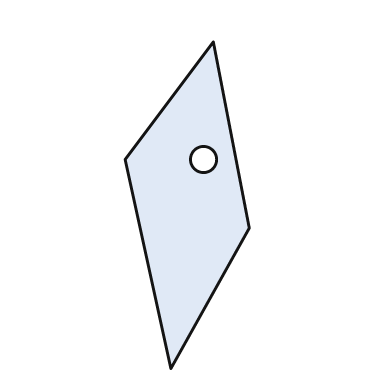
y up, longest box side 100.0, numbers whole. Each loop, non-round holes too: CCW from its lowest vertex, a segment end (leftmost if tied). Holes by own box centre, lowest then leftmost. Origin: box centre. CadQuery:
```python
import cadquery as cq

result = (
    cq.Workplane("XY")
    .moveTo(-5.0, -50.0)
    .lineTo(19.0, -7.0)
    .lineTo(8.0, 50.0)
    .lineTo(-19.0, 14.0)
    .close()
    .moveTo(5.0, 14.0)
    .circle(4.0)
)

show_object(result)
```